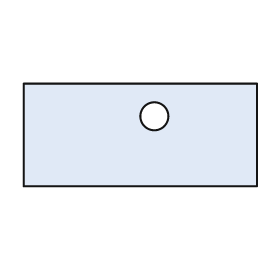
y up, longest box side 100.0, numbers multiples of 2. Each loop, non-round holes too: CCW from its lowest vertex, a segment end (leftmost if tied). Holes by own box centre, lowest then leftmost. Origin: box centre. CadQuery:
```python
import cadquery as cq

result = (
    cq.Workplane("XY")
    .moveTo(-50.0, -22.0)
    .lineTo(50.0, -22.0)
    .lineTo(50.0, 22.0)
    .lineTo(-50.0, 22.0)
    .close()
    .moveTo(6.0, 8.0)
    .circle(6.0)
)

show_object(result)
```